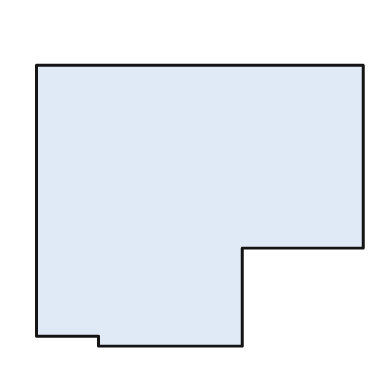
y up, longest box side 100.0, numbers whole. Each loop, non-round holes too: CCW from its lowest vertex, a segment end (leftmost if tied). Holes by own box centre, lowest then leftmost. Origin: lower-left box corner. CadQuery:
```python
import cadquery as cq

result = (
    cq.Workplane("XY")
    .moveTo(19.0, 0.0)
    .lineTo(63.0, 0.0)
    .lineTo(63.0, 30.0)
    .lineTo(100.0, 30.0)
    .lineTo(100.0, 86.0)
    .lineTo(0.0, 86.0)
    .lineTo(0.0, 3.0)
    .lineTo(19.0, 3.0)
    .close()
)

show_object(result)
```